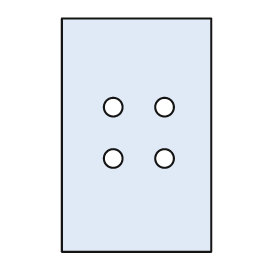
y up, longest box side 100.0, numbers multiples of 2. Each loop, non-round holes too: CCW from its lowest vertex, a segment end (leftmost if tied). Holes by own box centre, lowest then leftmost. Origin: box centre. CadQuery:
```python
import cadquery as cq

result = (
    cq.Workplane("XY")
    .moveTo(-32.0, -50.0)
    .lineTo(32.0, -50.0)
    .lineTo(32.0, 50.0)
    .lineTo(-32.0, 50.0)
    .close()
    .moveTo(-10.0, -10.0)
    .circle(4.0)
    .moveTo(12.0, -10.0)
    .circle(4.0)
    .moveTo(-10.0, 12.0)
    .circle(4.0)
    .moveTo(12.0, 12.0)
    .circle(4.0)
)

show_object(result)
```